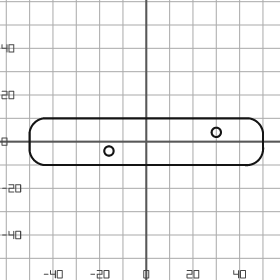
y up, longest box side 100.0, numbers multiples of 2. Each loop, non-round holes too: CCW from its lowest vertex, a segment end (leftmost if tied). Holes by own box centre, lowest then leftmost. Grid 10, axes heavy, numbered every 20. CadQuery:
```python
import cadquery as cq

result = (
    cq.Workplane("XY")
    .moveTo(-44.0, -10.0)
    .lineTo(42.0, -10.0)
    .threePointArc((48.0, -8.0), (50.0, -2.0))
    .lineTo(50.0, 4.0)
    .threePointArc((48.0, 8.0), (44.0, 10.0))
    .lineTo(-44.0, 10.0)
    .threePointArc((-48.0, 8.0), (-50.0, 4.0))
    .lineTo(-50.0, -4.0)
    .threePointArc((-48.0, -8.0), (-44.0, -10.0))
    .close()
    .moveTo(-16.0, -4.0)
    .circle(2.0)
    .moveTo(30.0, 4.0)
    .circle(2.0)
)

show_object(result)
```